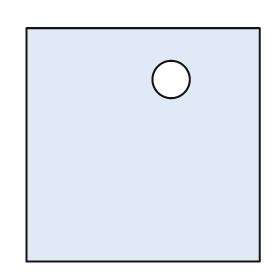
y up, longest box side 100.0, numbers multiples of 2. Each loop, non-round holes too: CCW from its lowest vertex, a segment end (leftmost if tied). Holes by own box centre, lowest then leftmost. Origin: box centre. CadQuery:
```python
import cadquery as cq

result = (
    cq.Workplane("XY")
    .moveTo(-50.0, -50.0)
    .lineTo(50.0, -50.0)
    .lineTo(50.0, 50.0)
    .lineTo(-50.0, 50.0)
    .close()
    .moveTo(12.0, 28.0)
    .circle(8.0)
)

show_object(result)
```